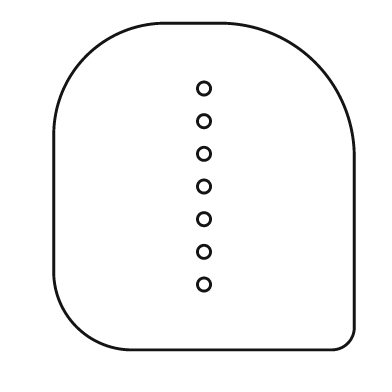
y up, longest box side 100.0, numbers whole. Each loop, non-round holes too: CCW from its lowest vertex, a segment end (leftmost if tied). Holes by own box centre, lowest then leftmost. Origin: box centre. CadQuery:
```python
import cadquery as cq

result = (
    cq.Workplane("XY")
    .moveTo(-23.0, -50.0)
    .lineTo(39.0, -50.0)
    .threePointArc((44.0, -48.0), (46.0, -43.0))
    .lineTo(46.0, 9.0)
    .threePointArc((34.0, 38.0), (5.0, 50.0))
    .lineTo(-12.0, 50.0)
    .threePointArc((-36.0, 40.0), (-46.0, 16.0))
    .lineTo(-46.0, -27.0)
    .threePointArc((-39.0, -43.0), (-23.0, -50.0))
    .close()
    .moveTo(0.0, -30.0)
    .circle(2.0)
    .moveTo(0.0, -20.0)
    .circle(2.0)
    .moveTo(0.0, -10.0)
    .circle(2.0)
    .moveTo(0.0, 0.0)
    .circle(2.0)
    .moveTo(0.0, 10.0)
    .circle(2.0)
    .moveTo(0.0, 20.0)
    .circle(2.0)
    .moveTo(0.0, 30.0)
    .circle(2.0)
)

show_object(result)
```